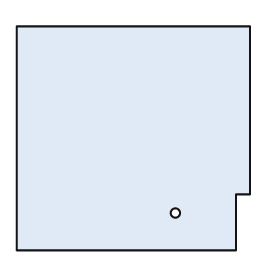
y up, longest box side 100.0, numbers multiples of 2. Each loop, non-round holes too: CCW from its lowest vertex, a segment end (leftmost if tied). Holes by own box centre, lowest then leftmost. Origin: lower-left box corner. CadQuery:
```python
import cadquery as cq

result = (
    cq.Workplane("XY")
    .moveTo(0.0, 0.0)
    .lineTo(94.0, 0.0)
    .lineTo(94.0, 24.0)
    .lineTo(100.0, 24.0)
    .lineTo(100.0, 96.0)
    .lineTo(0.0, 96.0)
    .close()
    .moveTo(68.0, 16.0)
    .circle(2.0)
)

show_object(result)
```